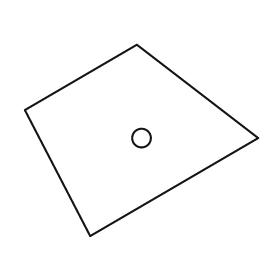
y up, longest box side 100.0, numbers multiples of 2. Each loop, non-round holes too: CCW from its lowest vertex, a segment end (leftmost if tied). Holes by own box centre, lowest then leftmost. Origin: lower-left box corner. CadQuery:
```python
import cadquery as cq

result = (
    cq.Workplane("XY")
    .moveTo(28.0, 0.0)
    .lineTo(100.0, 42.0)
    .lineTo(48.0, 82.0)
    .lineTo(0.0, 54.0)
    .close()
    .moveTo(50.0, 42.0)
    .circle(4.0)
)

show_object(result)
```